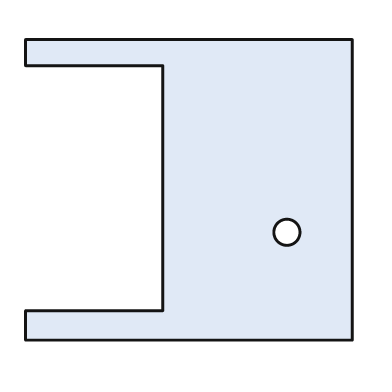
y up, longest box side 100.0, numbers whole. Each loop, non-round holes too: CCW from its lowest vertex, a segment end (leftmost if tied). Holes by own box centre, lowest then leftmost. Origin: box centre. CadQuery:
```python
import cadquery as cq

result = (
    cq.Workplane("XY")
    .moveTo(-50.0, -46.0)
    .lineTo(50.0, -46.0)
    .lineTo(50.0, 46.0)
    .lineTo(-50.0, 46.0)
    .lineTo(-50.0, 38.0)
    .lineTo(-8.0, 38.0)
    .lineTo(-8.0, -37.0)
    .lineTo(-50.0, -37.0)
    .close()
    .moveTo(30.0, -13.0)
    .circle(4.0)
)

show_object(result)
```